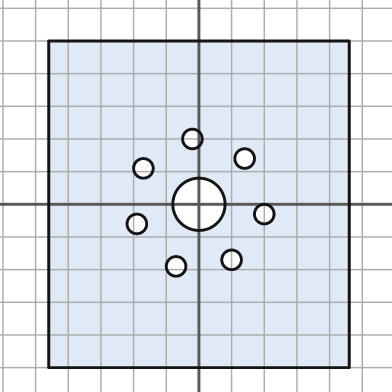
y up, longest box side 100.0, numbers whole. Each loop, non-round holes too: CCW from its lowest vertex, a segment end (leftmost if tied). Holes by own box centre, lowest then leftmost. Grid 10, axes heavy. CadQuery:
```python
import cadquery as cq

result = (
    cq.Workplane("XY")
    .moveTo(-46.0, -50.0)
    .lineTo(46.0, -50.0)
    .lineTo(46.0, 50.0)
    .lineTo(-46.0, 50.0)
    .close()
    .moveTo(-7.0, -19.0)
    .circle(3.0)
    .moveTo(10.0, -17.0)
    .circle(3.0)
    .moveTo(-19.0, -6.0)
    .circle(3.0)
    .moveTo(20.0, -3.0)
    .circle(3.0)
    .moveTo(0.0, 0.0)
    .circle(8.0)
    .moveTo(-17.0, 11.0)
    .circle(3.0)
    .moveTo(14.0, 14.0)
    .circle(3.0)
    .moveTo(-2.0, 20.0)
    .circle(3.0)
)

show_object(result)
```